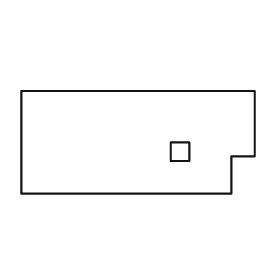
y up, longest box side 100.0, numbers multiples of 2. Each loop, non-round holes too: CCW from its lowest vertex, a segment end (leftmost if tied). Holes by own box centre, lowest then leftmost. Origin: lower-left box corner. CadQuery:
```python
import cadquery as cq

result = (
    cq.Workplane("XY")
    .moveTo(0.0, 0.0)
    .lineTo(90.0, 0.0)
    .lineTo(90.0, 16.0)
    .lineTo(100.0, 16.0)
    .lineTo(100.0, 44.0)
    .lineTo(0.0, 44.0)
    .close()
    .moveTo(64.0, 14.0)
    .lineTo(72.0, 14.0)
    .lineTo(72.0, 22.0)
    .lineTo(64.0, 22.0)
    .close()
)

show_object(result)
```